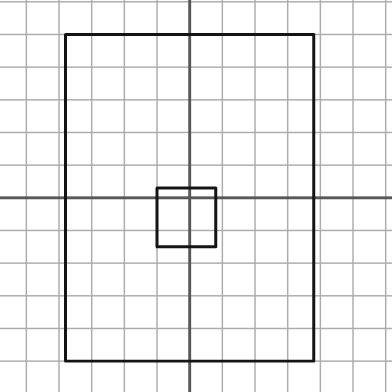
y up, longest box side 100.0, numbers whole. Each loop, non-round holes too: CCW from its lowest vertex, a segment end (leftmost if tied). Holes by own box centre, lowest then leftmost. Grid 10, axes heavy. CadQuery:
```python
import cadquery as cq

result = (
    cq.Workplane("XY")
    .moveTo(-38.0, -50.0)
    .lineTo(38.0, -50.0)
    .lineTo(38.0, 50.0)
    .lineTo(-38.0, 50.0)
    .close()
    .moveTo(-10.0, -15.0)
    .lineTo(8.0, -15.0)
    .lineTo(8.0, 3.0)
    .lineTo(-10.0, 3.0)
    .close()
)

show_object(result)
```